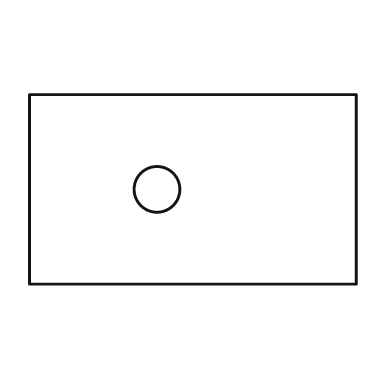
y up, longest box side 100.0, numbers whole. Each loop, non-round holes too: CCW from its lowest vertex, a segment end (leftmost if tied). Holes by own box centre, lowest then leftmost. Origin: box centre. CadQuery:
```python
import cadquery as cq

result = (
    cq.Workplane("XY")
    .moveTo(-50.0, -29.0)
    .lineTo(50.0, -29.0)
    .lineTo(50.0, 29.0)
    .lineTo(-50.0, 29.0)
    .close()
    .moveTo(-11.0, 0.0)
    .circle(7.0)
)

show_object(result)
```